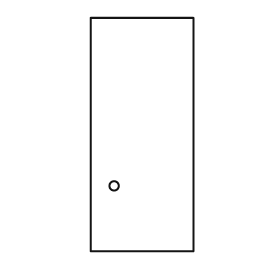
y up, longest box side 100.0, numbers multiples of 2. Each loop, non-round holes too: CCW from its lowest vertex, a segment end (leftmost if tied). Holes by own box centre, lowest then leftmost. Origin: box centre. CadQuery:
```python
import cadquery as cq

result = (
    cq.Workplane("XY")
    .moveTo(-22.0, -50.0)
    .lineTo(22.0, -50.0)
    .lineTo(22.0, 50.0)
    .lineTo(-22.0, 50.0)
    .close()
    .moveTo(-12.0, -22.0)
    .circle(2.0)
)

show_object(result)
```